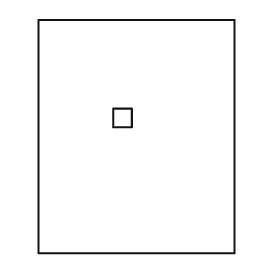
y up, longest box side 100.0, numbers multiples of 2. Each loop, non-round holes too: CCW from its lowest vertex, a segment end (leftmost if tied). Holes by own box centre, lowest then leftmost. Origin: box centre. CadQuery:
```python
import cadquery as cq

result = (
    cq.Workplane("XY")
    .moveTo(-42.0, -50.0)
    .lineTo(42.0, -50.0)
    .lineTo(42.0, 50.0)
    .lineTo(-42.0, 50.0)
    .close()
    .moveTo(-10.0, 4.0)
    .lineTo(-2.0, 4.0)
    .lineTo(-2.0, 12.0)
    .lineTo(-10.0, 12.0)
    .close()
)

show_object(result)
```